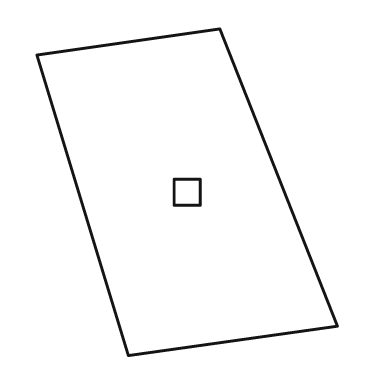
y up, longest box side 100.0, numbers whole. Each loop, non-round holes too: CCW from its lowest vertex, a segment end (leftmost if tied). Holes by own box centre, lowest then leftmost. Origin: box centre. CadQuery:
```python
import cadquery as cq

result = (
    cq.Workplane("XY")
    .moveTo(-18.0, -50.0)
    .lineTo(46.0, -41.0)
    .lineTo(10.0, 50.0)
    .lineTo(-46.0, 42.0)
    .close()
    .moveTo(-4.0, -4.0)
    .lineTo(4.0, -4.0)
    .lineTo(4.0, 4.0)
    .lineTo(-4.0, 4.0)
    .close()
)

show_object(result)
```